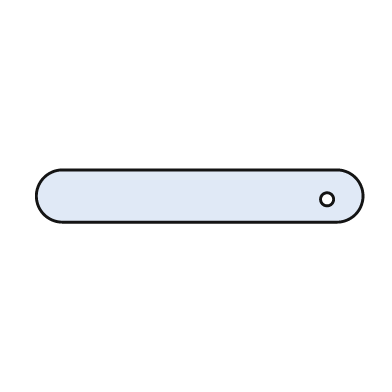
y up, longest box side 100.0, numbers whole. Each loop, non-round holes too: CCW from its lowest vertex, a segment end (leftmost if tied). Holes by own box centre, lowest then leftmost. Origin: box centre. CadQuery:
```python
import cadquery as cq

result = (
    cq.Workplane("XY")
    .moveTo(-42.0, -8.0)
    .lineTo(42.0, -8.0)
    .threePointArc((50.0, 0.0), (42.0, 8.0))
    .lineTo(-42.0, 8.0)
    .threePointArc((-50.0, 0.0), (-42.0, -8.0))
    .close()
    .moveTo(39.0, -1.0)
    .circle(2.0)
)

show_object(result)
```